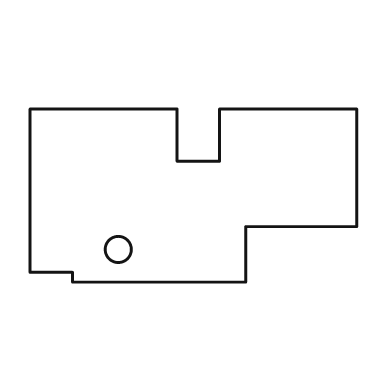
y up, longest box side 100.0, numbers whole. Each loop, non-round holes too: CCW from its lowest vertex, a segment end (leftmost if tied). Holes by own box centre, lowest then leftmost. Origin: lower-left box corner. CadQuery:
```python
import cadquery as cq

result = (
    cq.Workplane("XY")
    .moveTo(13.0, 0.0)
    .lineTo(66.0, 0.0)
    .lineTo(66.0, 17.0)
    .lineTo(100.0, 17.0)
    .lineTo(100.0, 53.0)
    .lineTo(58.0, 53.0)
    .lineTo(58.0, 37.0)
    .lineTo(45.0, 37.0)
    .lineTo(45.0, 53.0)
    .lineTo(0.0, 53.0)
    .lineTo(0.0, 3.0)
    .lineTo(13.0, 3.0)
    .close()
    .moveTo(27.0, 10.0)
    .circle(4.0)
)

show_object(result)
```